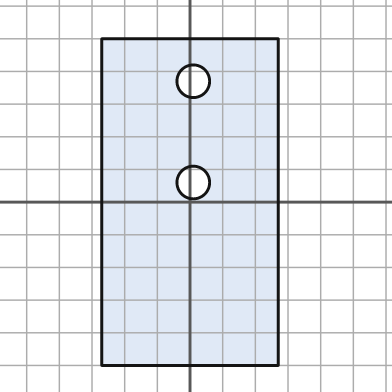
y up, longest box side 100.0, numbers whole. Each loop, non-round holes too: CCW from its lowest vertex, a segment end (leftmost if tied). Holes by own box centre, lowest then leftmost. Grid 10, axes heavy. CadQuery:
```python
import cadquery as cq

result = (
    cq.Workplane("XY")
    .moveTo(-27.0, -50.0)
    .lineTo(27.0, -50.0)
    .lineTo(27.0, 50.0)
    .lineTo(-27.0, 50.0)
    .close()
    .moveTo(1.0, 6.0)
    .circle(5.0)
    .moveTo(1.0, 37.0)
    .circle(5.0)
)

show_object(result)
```